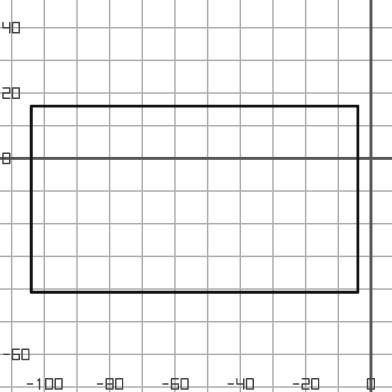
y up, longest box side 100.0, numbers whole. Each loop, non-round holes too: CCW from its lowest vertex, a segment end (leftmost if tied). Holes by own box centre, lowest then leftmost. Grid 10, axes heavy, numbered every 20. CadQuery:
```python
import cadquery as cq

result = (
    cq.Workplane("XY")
    .moveTo(-104.0, -41.0)
    .lineTo(-4.0, -41.0)
    .lineTo(-4.0, 16.0)
    .lineTo(-104.0, 16.0)
    .close()
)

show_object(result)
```